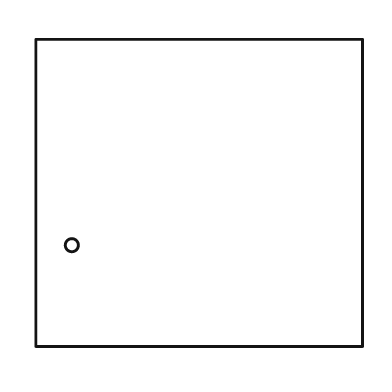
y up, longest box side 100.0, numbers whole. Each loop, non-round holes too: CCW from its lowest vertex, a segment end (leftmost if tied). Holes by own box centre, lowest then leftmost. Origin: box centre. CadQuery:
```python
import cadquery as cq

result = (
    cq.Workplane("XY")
    .moveTo(-50.0, -47.0)
    .lineTo(50.0, -47.0)
    .lineTo(50.0, 47.0)
    .lineTo(-50.0, 47.0)
    .close()
    .moveTo(-39.0, -16.0)
    .circle(2.0)
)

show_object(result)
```